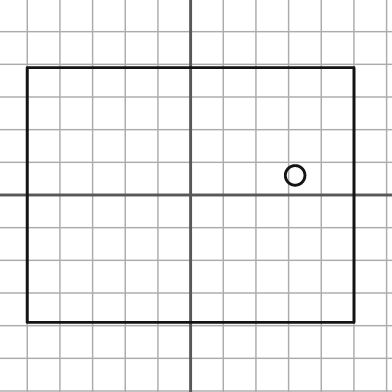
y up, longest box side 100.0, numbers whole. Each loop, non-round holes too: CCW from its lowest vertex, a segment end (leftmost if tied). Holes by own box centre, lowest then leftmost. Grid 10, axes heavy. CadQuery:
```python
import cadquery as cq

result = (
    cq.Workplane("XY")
    .moveTo(-50.0, -39.0)
    .lineTo(50.0, -39.0)
    .lineTo(50.0, 39.0)
    .lineTo(-50.0, 39.0)
    .close()
    .moveTo(32.0, 6.0)
    .circle(3.0)
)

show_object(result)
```